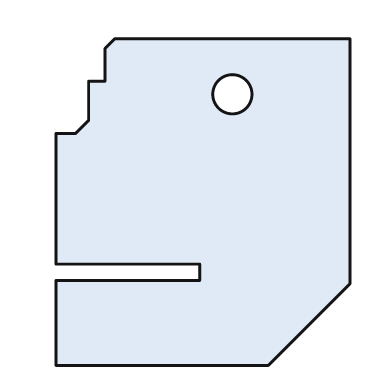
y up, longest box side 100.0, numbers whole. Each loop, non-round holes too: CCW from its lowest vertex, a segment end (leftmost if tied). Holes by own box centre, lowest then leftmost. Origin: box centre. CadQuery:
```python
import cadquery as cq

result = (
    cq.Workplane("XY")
    .moveTo(-45.0, -50.0)
    .lineTo(20.0, -50.0)
    .lineTo(45.0, -25.0)
    .lineTo(45.0, 50.0)
    .lineTo(-27.0, 50.0)
    .lineTo(-30.0, 47.0)
    .lineTo(-30.0, 37.0)
    .lineTo(-35.0, 37.0)
    .lineTo(-35.0, 25.0)
    .lineTo(-39.0, 21.0)
    .lineTo(-45.0, 21.0)
    .lineTo(-45.0, -19.0)
    .lineTo(-1.0, -19.0)
    .lineTo(-1.0, -24.0)
    .lineTo(-45.0, -24.0)
    .close()
    .moveTo(9.0, 33.0)
    .circle(6.0)
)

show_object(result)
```